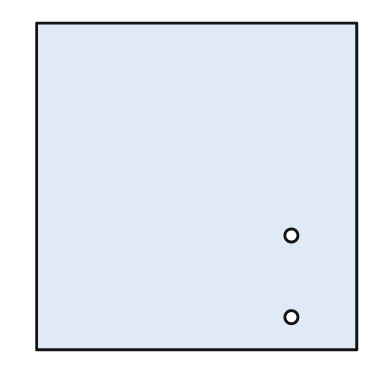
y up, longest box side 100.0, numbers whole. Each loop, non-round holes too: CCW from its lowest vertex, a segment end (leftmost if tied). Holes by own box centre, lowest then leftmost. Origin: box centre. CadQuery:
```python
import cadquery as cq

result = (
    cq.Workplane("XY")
    .moveTo(-49.0, -50.0)
    .lineTo(49.0, -50.0)
    .lineTo(49.0, 50.0)
    .lineTo(-49.0, 50.0)
    .close()
    .moveTo(29.0, -40.0)
    .circle(2.0)
    .moveTo(29.0, -15.0)
    .circle(2.0)
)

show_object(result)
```